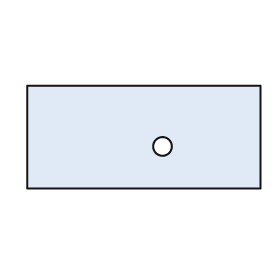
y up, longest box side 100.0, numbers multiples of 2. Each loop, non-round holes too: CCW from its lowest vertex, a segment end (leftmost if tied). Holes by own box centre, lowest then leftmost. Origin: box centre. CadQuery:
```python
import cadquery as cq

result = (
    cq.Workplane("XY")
    .moveTo(-50.0, -22.0)
    .lineTo(50.0, -22.0)
    .lineTo(50.0, 22.0)
    .lineTo(-50.0, 22.0)
    .close()
    .moveTo(8.0, -4.0)
    .circle(4.0)
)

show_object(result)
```